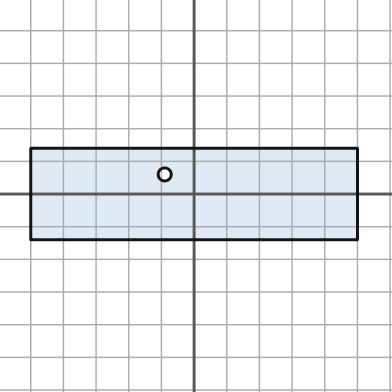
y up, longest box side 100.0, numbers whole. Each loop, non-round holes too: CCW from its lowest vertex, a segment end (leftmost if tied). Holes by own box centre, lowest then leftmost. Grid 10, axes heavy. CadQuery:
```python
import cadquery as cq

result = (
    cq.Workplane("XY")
    .moveTo(-50.0, -14.0)
    .lineTo(50.0, -14.0)
    .lineTo(50.0, 14.0)
    .lineTo(-50.0, 14.0)
    .close()
    .moveTo(-9.0, 6.0)
    .circle(2.0)
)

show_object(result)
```